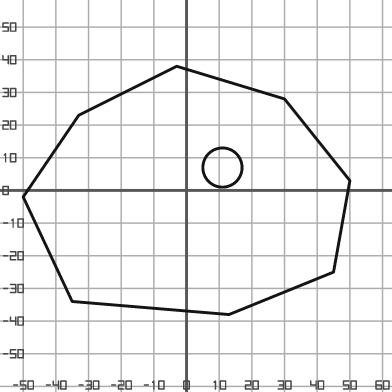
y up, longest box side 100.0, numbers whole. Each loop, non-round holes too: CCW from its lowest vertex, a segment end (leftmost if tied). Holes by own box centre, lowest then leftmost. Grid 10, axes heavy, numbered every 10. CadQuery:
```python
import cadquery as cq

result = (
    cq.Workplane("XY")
    .moveTo(13.0, -38.0)
    .lineTo(45.0, -25.0)
    .lineTo(50.0, 3.0)
    .lineTo(30.0, 28.0)
    .lineTo(-3.0, 38.0)
    .lineTo(-33.0, 23.0)
    .lineTo(-50.0, -2.0)
    .lineTo(-35.0, -34.0)
    .close()
    .moveTo(11.0, 7.0)
    .circle(6.0)
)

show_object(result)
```